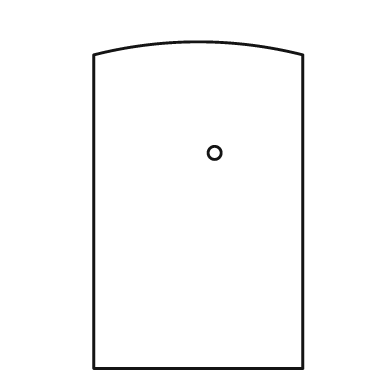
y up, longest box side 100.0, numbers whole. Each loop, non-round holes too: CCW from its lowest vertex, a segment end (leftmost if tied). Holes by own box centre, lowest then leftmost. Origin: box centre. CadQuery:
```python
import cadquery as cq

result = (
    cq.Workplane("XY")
    .moveTo(-32.0, -50.0)
    .lineTo(32.0, -50.0)
    .lineTo(32.0, 46.0)
    .threePointArc((0.0, 50.0), (-32.0, 46.0))
    .close()
    .moveTo(5.0, 16.0)
    .circle(2.0)
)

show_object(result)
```